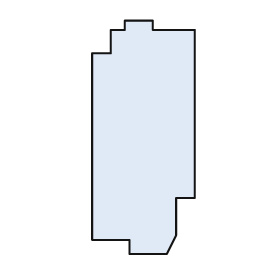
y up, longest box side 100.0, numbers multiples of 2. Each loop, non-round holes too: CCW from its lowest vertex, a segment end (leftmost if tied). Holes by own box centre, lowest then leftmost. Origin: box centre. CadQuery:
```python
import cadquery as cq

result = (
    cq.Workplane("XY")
    .moveTo(-6.0, -50.0)
    .lineTo(10.0, -50.0)
    .lineTo(14.0, -42.0)
    .lineTo(14.0, -26.0)
    .lineTo(22.0, -26.0)
    .lineTo(22.0, 46.0)
    .lineTo(4.0, 46.0)
    .lineTo(4.0, 50.0)
    .lineTo(-8.0, 50.0)
    .lineTo(-8.0, 46.0)
    .lineTo(-14.0, 46.0)
    .lineTo(-14.0, 36.0)
    .lineTo(-22.0, 36.0)
    .lineTo(-22.0, -44.0)
    .lineTo(-6.0, -44.0)
    .close()
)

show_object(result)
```